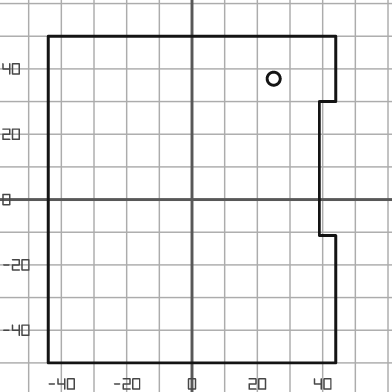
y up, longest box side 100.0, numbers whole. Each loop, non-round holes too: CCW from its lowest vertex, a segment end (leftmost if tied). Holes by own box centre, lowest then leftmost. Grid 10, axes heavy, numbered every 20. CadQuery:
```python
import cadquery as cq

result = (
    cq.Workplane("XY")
    .moveTo(-44.0, -50.0)
    .lineTo(44.0, -50.0)
    .lineTo(44.0, -11.0)
    .lineTo(39.0, -11.0)
    .lineTo(39.0, 30.0)
    .lineTo(44.0, 30.0)
    .lineTo(44.0, 50.0)
    .lineTo(-44.0, 50.0)
    .close()
    .moveTo(25.0, 37.0)
    .circle(2.0)
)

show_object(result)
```